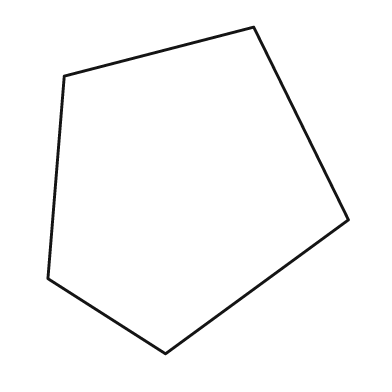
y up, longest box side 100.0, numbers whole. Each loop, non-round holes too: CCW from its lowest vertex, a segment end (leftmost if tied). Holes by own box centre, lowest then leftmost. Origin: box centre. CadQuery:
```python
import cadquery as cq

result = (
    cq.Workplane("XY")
    .moveTo(-10.0, -50.0)
    .lineTo(46.0, -9.0)
    .lineTo(17.0, 50.0)
    .lineTo(-41.0, 35.0)
    .lineTo(-46.0, -27.0)
    .close()
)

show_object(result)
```